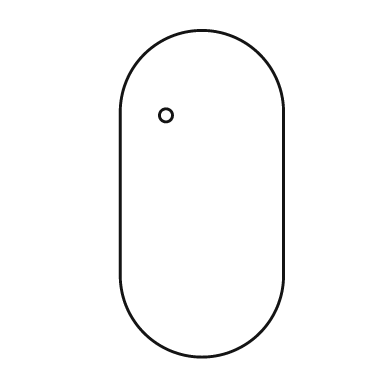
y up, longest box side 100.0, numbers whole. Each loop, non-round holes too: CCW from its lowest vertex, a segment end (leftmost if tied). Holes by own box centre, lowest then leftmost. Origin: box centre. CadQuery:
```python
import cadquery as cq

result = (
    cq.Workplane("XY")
    .moveTo(-25.0, -25.0)
    .threePointArc((0.0, -50.0), (25.0, -25.0))
    .lineTo(25.0, 25.0)
    .threePointArc((0.0, 50.0), (-25.0, 25.0))
    .close()
    .moveTo(-11.0, 24.0)
    .circle(2.0)
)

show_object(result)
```